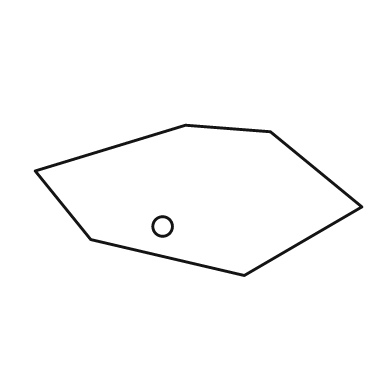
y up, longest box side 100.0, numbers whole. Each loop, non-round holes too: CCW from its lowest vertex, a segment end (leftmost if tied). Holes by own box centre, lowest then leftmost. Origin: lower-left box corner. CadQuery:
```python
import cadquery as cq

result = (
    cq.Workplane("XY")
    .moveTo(64.0, 0.0)
    .lineTo(100.0, 21.0)
    .lineTo(72.0, 44.0)
    .lineTo(46.0, 46.0)
    .lineTo(0.0, 32.0)
    .lineTo(17.0, 11.0)
    .close()
    .moveTo(39.0, 15.0)
    .circle(3.0)
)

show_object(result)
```